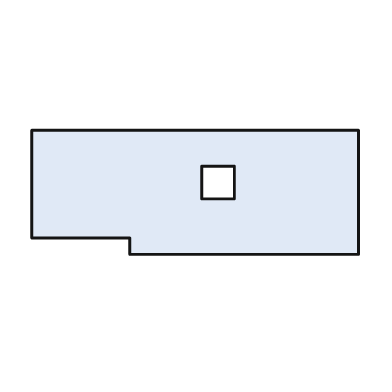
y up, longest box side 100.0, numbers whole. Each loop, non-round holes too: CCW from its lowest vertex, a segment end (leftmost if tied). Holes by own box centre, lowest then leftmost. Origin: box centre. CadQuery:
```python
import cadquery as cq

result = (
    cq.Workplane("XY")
    .moveTo(-20.0, -19.0)
    .lineTo(50.0, -19.0)
    .lineTo(50.0, 19.0)
    .lineTo(-50.0, 19.0)
    .lineTo(-50.0, -14.0)
    .lineTo(-20.0, -14.0)
    .close()
    .moveTo(2.0, -2.0)
    .lineTo(12.0, -2.0)
    .lineTo(12.0, 8.0)
    .lineTo(2.0, 8.0)
    .close()
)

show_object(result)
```